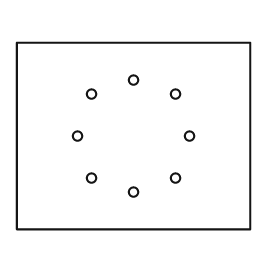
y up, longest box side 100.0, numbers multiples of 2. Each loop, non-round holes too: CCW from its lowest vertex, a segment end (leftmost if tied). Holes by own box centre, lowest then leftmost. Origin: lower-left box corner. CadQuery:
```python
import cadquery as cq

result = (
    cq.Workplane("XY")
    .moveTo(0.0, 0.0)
    .lineTo(100.0, 0.0)
    .lineTo(100.0, 80.0)
    .lineTo(0.0, 80.0)
    .close()
    .moveTo(50.0, 16.0)
    .circle(2.0)
    .moveTo(32.0, 22.0)
    .circle(2.0)
    .moveTo(68.0, 22.0)
    .circle(2.0)
    .moveTo(26.0, 40.0)
    .circle(2.0)
    .moveTo(74.0, 40.0)
    .circle(2.0)
    .moveTo(32.0, 58.0)
    .circle(2.0)
    .moveTo(68.0, 58.0)
    .circle(2.0)
    .moveTo(50.0, 64.0)
    .circle(2.0)
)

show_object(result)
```